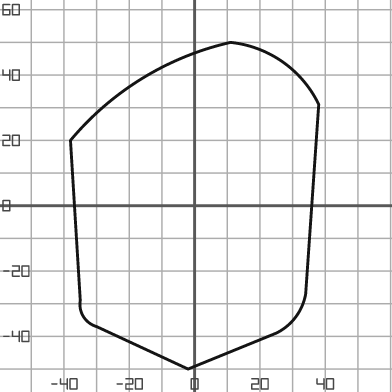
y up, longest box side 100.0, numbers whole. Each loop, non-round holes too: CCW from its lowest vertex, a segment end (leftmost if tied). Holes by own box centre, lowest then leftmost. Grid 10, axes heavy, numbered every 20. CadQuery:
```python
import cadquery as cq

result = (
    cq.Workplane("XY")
    .moveTo(-2.0, -50.0)
    .lineTo(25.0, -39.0)
    .threePointArc((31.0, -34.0), (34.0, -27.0))
    .lineTo(38.0, 31.0)
    .threePointArc((27.0, 44.0), (11.0, 50.0))
    .threePointArc((-16.0, 39.0), (-38.0, 20.0))
    .lineTo(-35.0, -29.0)
    .threePointArc((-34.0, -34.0), (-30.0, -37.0))
    .close()
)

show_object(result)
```